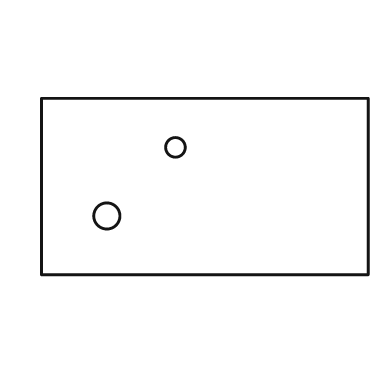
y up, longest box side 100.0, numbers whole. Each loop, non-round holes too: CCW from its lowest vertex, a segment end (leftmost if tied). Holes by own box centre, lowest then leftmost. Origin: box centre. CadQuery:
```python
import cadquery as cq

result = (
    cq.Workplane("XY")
    .moveTo(-50.0, -27.0)
    .lineTo(50.0, -27.0)
    .lineTo(50.0, 27.0)
    .lineTo(-50.0, 27.0)
    .close()
    .moveTo(-30.0, -9.0)
    .circle(4.0)
    .moveTo(-9.0, 12.0)
    .circle(3.0)
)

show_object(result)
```